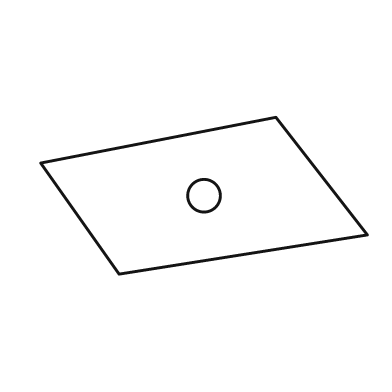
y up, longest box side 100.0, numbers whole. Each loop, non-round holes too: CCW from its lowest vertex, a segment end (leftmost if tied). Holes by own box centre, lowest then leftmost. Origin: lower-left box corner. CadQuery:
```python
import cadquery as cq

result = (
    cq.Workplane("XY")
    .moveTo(24.0, 0.0)
    .lineTo(100.0, 12.0)
    .lineTo(72.0, 48.0)
    .lineTo(0.0, 34.0)
    .close()
    .moveTo(50.0, 24.0)
    .circle(5.0)
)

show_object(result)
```